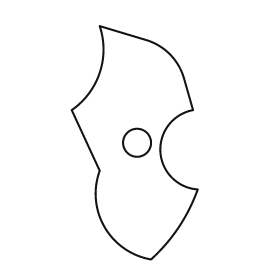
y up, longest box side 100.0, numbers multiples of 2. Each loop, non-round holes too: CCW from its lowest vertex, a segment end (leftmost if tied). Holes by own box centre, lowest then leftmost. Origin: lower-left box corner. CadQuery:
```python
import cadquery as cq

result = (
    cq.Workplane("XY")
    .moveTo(34.0, 0.0)
    .threePointArc((46.0, 14.0), (54.0, 30.0))
    .threePointArc((38.0, 46.0), (52.0, 64.0))
    .lineTo(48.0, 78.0)
    .threePointArc((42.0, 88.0), (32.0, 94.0))
    .lineTo(12.0, 100.0)
    .threePointArc((12.0, 80.0), (0.0, 64.0))
    .lineTo(12.0, 38.0)
    .threePointArc((14.0, 14.0), (34.0, 0.0))
    .close()
    .moveTo(28.0, 50.0)
    .circle(6.0)
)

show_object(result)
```